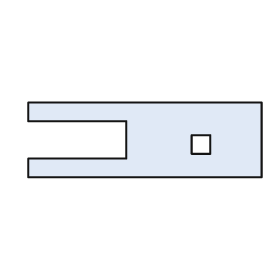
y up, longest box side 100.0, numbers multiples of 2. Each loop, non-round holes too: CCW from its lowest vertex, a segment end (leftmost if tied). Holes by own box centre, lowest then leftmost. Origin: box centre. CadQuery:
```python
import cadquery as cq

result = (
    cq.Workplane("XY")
    .moveTo(-50.0, -16.0)
    .lineTo(50.0, -16.0)
    .lineTo(50.0, 16.0)
    .lineTo(-50.0, 16.0)
    .lineTo(-50.0, 8.0)
    .lineTo(-8.0, 8.0)
    .lineTo(-8.0, -8.0)
    .lineTo(-50.0, -8.0)
    .close()
    .moveTo(20.0, -6.0)
    .lineTo(28.0, -6.0)
    .lineTo(28.0, 2.0)
    .lineTo(20.0, 2.0)
    .close()
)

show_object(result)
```